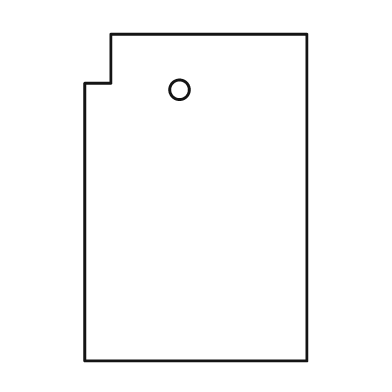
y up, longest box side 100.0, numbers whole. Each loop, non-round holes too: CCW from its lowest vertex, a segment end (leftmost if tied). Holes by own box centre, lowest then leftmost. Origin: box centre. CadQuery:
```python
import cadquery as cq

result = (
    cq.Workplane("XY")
    .moveTo(-34.0, -50.0)
    .lineTo(34.0, -50.0)
    .lineTo(34.0, 50.0)
    .lineTo(-26.0, 50.0)
    .lineTo(-26.0, 35.0)
    .lineTo(-34.0, 35.0)
    .close()
    .moveTo(-5.0, 33.0)
    .circle(3.0)
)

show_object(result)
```